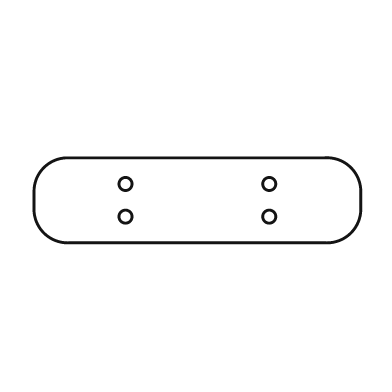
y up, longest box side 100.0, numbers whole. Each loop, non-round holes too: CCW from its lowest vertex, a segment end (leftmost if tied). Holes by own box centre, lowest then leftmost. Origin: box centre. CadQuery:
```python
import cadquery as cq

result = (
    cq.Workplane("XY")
    .moveTo(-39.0, -13.0)
    .lineTo(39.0, -13.0)
    .threePointArc((47.0, -10.0), (50.0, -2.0))
    .lineTo(50.0, 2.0)
    .threePointArc((47.0, 10.0), (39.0, 13.0))
    .lineTo(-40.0, 13.0)
    .threePointArc((-47.0, 10.0), (-50.0, 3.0))
    .lineTo(-50.0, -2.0)
    .threePointArc((-47.0, -10.0), (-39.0, -13.0))
    .close()
    .moveTo(-22.0, -5.0)
    .circle(2.0)
    .moveTo(22.0, -5.0)
    .circle(2.0)
    .moveTo(-22.0, 5.0)
    .circle(2.0)
    .moveTo(22.0, 5.0)
    .circle(2.0)
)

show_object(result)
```